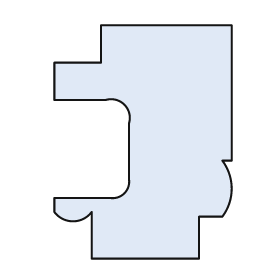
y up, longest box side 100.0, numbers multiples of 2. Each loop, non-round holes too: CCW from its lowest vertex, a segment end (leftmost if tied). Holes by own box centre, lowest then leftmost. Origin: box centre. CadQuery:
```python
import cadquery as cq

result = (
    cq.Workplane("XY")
    .moveTo(-22.0, -50.0)
    .lineTo(24.0, -50.0)
    .lineTo(24.0, -32.0)
    .lineTo(34.0, -32.0)
    .threePointArc((38.0, -20.0), (34.0, -8.0))
    .lineTo(38.0, -8.0)
    .lineTo(38.0, 50.0)
    .lineTo(-18.0, 50.0)
    .lineTo(-18.0, 34.0)
    .lineTo(-38.0, 34.0)
    .lineTo(-38.0, 18.0)
    .lineTo(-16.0, 18.0)
    .threePointArc((-8.0, 16.0), (-6.0, 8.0))
    .lineTo(-6.0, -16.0)
    .threePointArc((-8.0, -22.0), (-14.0, -24.0))
    .lineTo(-38.0, -24.0)
    .lineTo(-38.0, -30.0)
    .threePointArc((-30.0, -34.0), (-22.0, -30.0))
    .close()
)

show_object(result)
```